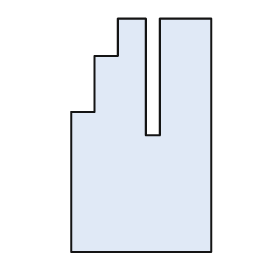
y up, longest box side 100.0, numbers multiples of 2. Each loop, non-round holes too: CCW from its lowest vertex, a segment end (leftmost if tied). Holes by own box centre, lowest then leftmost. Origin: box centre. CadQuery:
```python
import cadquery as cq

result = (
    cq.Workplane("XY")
    .moveTo(-30.0, -50.0)
    .lineTo(30.0, -50.0)
    .lineTo(30.0, 50.0)
    .lineTo(8.0, 50.0)
    .lineTo(8.0, 0.0)
    .lineTo(2.0, 0.0)
    .lineTo(2.0, 50.0)
    .lineTo(-10.0, 50.0)
    .lineTo(-10.0, 34.0)
    .lineTo(-20.0, 34.0)
    .lineTo(-20.0, 10.0)
    .lineTo(-30.0, 10.0)
    .close()
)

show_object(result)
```